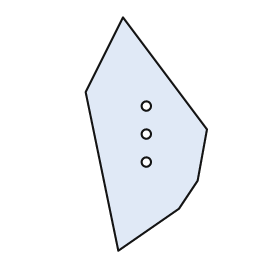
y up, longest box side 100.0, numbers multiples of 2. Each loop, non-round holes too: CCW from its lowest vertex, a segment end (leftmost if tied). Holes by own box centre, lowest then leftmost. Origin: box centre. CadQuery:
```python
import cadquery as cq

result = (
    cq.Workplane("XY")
    .moveTo(-12.0, -50.0)
    .lineTo(14.0, -32.0)
    .lineTo(22.0, -20.0)
    .lineTo(26.0, 2.0)
    .lineTo(-10.0, 50.0)
    .lineTo(-26.0, 18.0)
    .close()
    .moveTo(0.0, -12.0)
    .circle(2.0)
    .moveTo(0.0, 0.0)
    .circle(2.0)
    .moveTo(0.0, 12.0)
    .circle(2.0)
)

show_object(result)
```